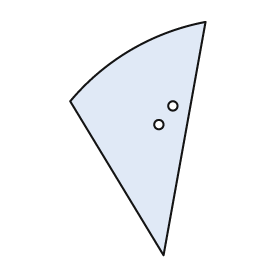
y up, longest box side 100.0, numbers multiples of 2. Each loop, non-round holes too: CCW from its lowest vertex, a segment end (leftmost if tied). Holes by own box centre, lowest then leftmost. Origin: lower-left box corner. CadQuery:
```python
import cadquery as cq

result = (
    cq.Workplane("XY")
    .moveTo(40.0, 0.0)
    .lineTo(58.0, 100.0)
    .threePointArc((26.0, 88.0), (0.0, 66.0))
    .close()
    .moveTo(38.0, 56.0)
    .circle(2.0)
    .moveTo(44.0, 64.0)
    .circle(2.0)
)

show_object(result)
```